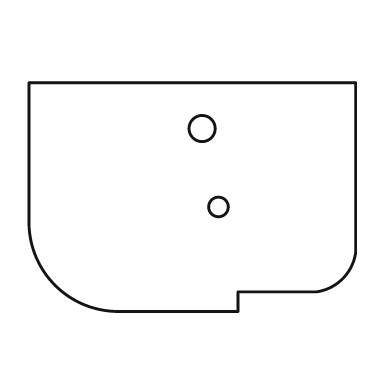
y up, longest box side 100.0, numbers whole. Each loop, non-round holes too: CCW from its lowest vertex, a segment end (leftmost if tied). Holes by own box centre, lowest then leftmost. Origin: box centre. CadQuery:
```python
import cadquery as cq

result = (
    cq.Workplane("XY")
    .moveTo(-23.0, -35.0)
    .lineTo(14.0, -35.0)
    .lineTo(14.0, -29.0)
    .lineTo(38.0, -29.0)
    .threePointArc((46.0, -25.0), (50.0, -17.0))
    .lineTo(50.0, 35.0)
    .lineTo(-50.0, 35.0)
    .lineTo(-50.0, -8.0)
    .threePointArc((-42.0, -27.0), (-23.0, -35.0))
    .close()
    .moveTo(8.0, -3.0)
    .circle(3.0)
    .moveTo(3.0, 21.0)
    .circle(4.0)
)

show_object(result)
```